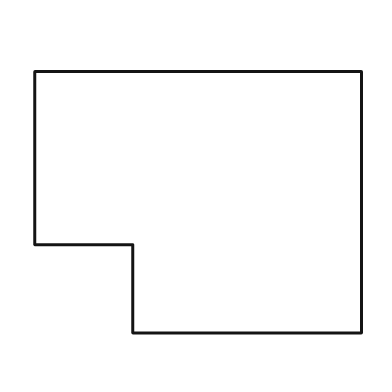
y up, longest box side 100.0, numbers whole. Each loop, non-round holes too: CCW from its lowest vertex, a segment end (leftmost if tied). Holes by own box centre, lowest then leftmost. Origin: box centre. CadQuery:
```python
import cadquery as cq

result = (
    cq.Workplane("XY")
    .moveTo(-20.0, -40.0)
    .lineTo(50.0, -40.0)
    .lineTo(50.0, 40.0)
    .lineTo(-50.0, 40.0)
    .lineTo(-50.0, -13.0)
    .lineTo(-20.0, -13.0)
    .close()
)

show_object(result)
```